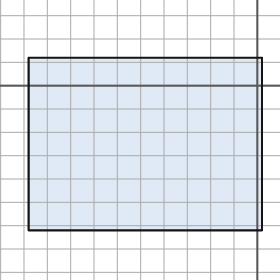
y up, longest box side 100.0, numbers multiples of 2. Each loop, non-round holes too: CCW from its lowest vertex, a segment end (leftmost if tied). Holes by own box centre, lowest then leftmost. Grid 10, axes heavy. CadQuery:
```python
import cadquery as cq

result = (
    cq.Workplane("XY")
    .moveTo(-98.0, -62.0)
    .lineTo(2.0, -62.0)
    .lineTo(2.0, 12.0)
    .lineTo(-98.0, 12.0)
    .close()
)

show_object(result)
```